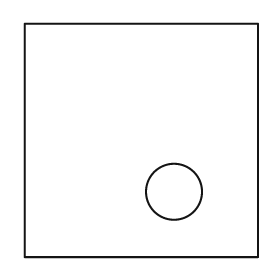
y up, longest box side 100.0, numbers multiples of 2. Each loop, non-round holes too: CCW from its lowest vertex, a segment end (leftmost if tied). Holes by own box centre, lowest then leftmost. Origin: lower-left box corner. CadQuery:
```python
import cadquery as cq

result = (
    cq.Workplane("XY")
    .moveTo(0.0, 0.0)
    .lineTo(100.0, 0.0)
    .lineTo(100.0, 100.0)
    .lineTo(0.0, 100.0)
    .close()
    .moveTo(64.0, 28.0)
    .circle(12.0)
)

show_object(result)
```